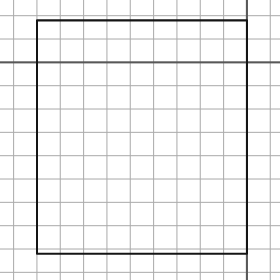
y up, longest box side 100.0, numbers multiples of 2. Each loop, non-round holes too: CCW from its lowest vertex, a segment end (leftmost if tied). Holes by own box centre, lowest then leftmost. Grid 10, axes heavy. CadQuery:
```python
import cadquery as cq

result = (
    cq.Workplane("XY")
    .moveTo(-90.0, -82.0)
    .lineTo(0.0, -82.0)
    .lineTo(0.0, 18.0)
    .lineTo(-90.0, 18.0)
    .close()
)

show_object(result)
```